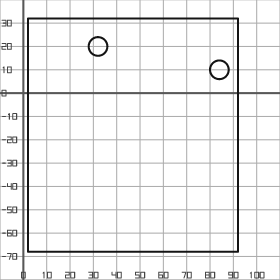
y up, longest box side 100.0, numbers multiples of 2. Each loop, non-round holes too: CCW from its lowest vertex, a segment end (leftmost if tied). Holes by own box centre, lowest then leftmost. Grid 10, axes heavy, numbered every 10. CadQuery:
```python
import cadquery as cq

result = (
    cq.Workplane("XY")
    .moveTo(2.0, -68.0)
    .lineTo(92.0, -68.0)
    .lineTo(92.0, 32.0)
    .lineTo(2.0, 32.0)
    .close()
    .moveTo(84.0, 10.0)
    .circle(4.0)
    .moveTo(32.0, 20.0)
    .circle(4.0)
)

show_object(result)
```